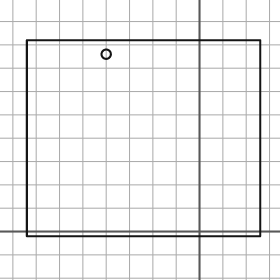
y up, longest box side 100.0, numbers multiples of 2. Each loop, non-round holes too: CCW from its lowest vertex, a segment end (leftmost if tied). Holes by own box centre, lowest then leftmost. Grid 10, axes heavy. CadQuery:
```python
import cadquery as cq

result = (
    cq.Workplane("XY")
    .moveTo(-74.0, -2.0)
    .lineTo(26.0, -2.0)
    .lineTo(26.0, 82.0)
    .lineTo(-74.0, 82.0)
    .close()
    .moveTo(-40.0, 76.0)
    .circle(2.0)
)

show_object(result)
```